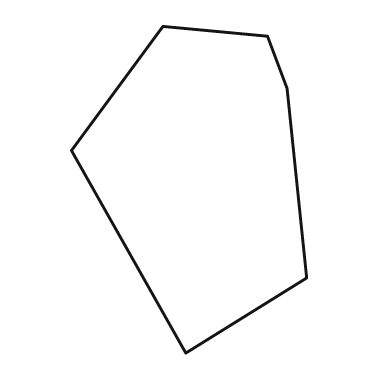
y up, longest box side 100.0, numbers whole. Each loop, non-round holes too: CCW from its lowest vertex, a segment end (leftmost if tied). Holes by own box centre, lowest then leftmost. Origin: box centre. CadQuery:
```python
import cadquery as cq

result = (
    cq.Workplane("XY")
    .moveTo(-1.0, -50.0)
    .lineTo(36.0, -27.0)
    .lineTo(30.0, 31.0)
    .lineTo(24.0, 47.0)
    .lineTo(-8.0, 50.0)
    .lineTo(-36.0, 12.0)
    .close()
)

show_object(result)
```